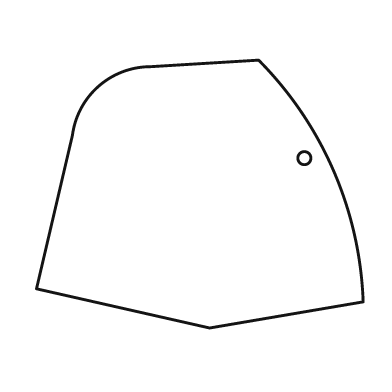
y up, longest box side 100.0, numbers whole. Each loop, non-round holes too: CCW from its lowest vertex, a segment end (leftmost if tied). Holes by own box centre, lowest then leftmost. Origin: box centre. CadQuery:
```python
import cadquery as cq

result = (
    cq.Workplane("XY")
    .moveTo(3.0, -41.0)
    .lineTo(50.0, -33.0)
    .threePointArc((41.0, 7.0), (18.0, 41.0))
    .lineTo(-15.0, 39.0)
    .threePointArc((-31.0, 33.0), (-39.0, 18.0))
    .lineTo(-50.0, -29.0)
    .close()
    .moveTo(32.0, 11.0)
    .circle(2.0)
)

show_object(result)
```